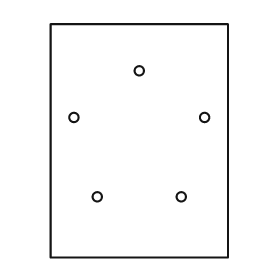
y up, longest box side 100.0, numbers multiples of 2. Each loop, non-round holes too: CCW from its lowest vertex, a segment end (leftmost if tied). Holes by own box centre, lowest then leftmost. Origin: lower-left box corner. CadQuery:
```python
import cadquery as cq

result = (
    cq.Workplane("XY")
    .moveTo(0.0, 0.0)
    .lineTo(76.0, 0.0)
    .lineTo(76.0, 100.0)
    .lineTo(0.0, 100.0)
    .close()
    .moveTo(20.0, 26.0)
    .circle(2.0)
    .moveTo(56.0, 26.0)
    .circle(2.0)
    .moveTo(10.0, 60.0)
    .circle(2.0)
    .moveTo(66.0, 60.0)
    .circle(2.0)
    .moveTo(38.0, 80.0)
    .circle(2.0)
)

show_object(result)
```